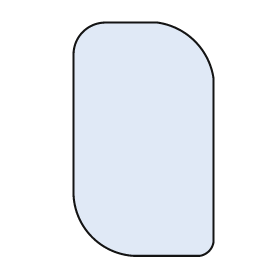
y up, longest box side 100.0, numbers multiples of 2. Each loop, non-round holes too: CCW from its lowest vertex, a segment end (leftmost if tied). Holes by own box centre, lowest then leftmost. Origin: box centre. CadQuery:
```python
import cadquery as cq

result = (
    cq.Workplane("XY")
    .moveTo(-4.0, -50.0)
    .lineTo(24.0, -50.0)
    .threePointArc((28.0, -48.0), (30.0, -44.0))
    .lineTo(30.0, 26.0)
    .threePointArc((22.0, 42.0), (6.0, 50.0))
    .lineTo(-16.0, 50.0)
    .threePointArc((-26.0, 46.0), (-30.0, 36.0))
    .lineTo(-30.0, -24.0)
    .threePointArc((-22.0, -42.0), (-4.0, -50.0))
    .close()
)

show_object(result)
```